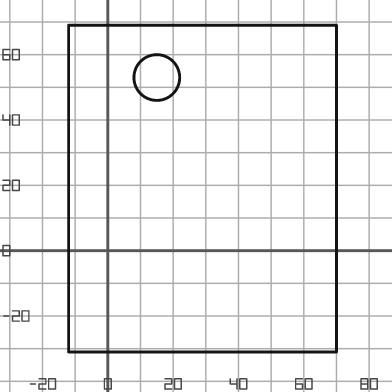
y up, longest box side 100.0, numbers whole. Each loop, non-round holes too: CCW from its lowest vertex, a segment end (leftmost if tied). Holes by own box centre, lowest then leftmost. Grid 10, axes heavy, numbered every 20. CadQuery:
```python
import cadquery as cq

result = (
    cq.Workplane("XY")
    .moveTo(-12.0, -31.0)
    .lineTo(70.0, -31.0)
    .lineTo(70.0, 69.0)
    .lineTo(-12.0, 69.0)
    .close()
    .moveTo(15.0, 53.0)
    .circle(7.0)
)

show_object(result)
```